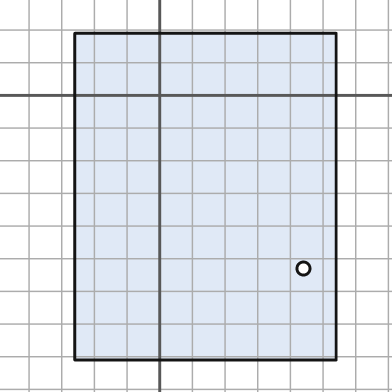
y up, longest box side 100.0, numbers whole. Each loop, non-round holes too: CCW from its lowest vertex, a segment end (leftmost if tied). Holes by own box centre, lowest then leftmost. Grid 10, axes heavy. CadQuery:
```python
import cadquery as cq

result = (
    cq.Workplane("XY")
    .moveTo(-26.0, -81.0)
    .lineTo(54.0, -81.0)
    .lineTo(54.0, 19.0)
    .lineTo(-26.0, 19.0)
    .close()
    .moveTo(44.0, -53.0)
    .circle(2.0)
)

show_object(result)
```